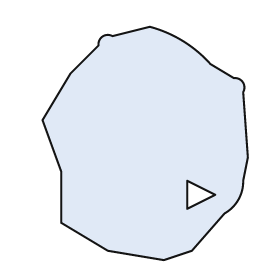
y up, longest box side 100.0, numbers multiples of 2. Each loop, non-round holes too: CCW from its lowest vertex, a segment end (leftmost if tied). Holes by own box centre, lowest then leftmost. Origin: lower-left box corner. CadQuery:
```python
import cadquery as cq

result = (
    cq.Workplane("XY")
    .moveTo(52.0, 0.0)
    .lineTo(64.0, 4.0)
    .lineTo(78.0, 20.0)
    .threePointArc((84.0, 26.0), (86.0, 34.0))
    .lineTo(88.0, 44.0)
    .lineTo(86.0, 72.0)
    .threePointArc((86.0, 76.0), (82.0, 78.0))
    .lineTo(72.0, 84.0)
    .threePointArc((60.0, 94.0), (46.0, 100.0))
    .lineTo(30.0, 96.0)
    .threePointArc((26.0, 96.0), (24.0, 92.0))
    .lineTo(12.0, 80.0)
    .lineTo(0.0, 60.0)
    .lineTo(8.0, 38.0)
    .lineTo(8.0, 16.0)
    .lineTo(28.0, 4.0)
    .close()
    .moveTo(62.0, 22.0)
    .lineTo(74.0, 28.0)
    .lineTo(62.0, 34.0)
    .close()
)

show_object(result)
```